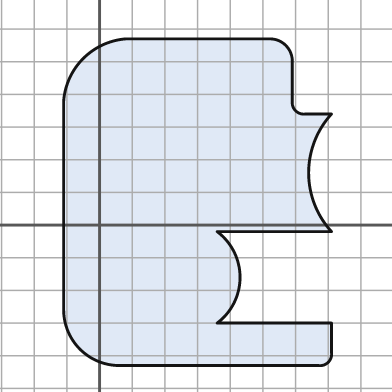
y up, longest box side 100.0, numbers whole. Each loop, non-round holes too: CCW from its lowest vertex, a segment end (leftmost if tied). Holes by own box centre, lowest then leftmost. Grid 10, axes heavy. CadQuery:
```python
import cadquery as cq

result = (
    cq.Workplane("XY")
    .moveTo(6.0, -43.0)
    .lineTo(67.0, -43.0)
    .threePointArc((70.0, -42.0), (71.0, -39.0))
    .lineTo(71.0, -30.0)
    .lineTo(36.0, -30.0)
    .threePointArc((43.0, -16.0), (36.0, -2.0))
    .lineTo(71.0, -2.0)
    .threePointArc((64.0, 16.0), (71.0, 34.0))
    .lineTo(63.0, 34.0)
    .threePointArc((60.0, 35.0), (59.0, 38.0))
    .lineTo(59.0, 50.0)
    .threePointArc((57.0, 55.0), (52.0, 57.0))
    .lineTo(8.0, 57.0)
    .threePointArc((-5.0, 51.0), (-11.0, 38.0))
    .lineTo(-11.0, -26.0)
    .threePointArc((-6.0, -38.0), (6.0, -43.0))
    .close()
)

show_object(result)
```